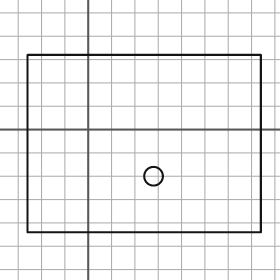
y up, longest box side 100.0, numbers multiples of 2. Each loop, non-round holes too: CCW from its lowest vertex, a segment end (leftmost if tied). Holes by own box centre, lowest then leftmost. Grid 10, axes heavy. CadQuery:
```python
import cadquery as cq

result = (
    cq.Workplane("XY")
    .moveTo(-26.0, -44.0)
    .lineTo(74.0, -44.0)
    .lineTo(74.0, 32.0)
    .lineTo(-26.0, 32.0)
    .close()
    .moveTo(28.0, -20.0)
    .circle(4.0)
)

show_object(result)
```